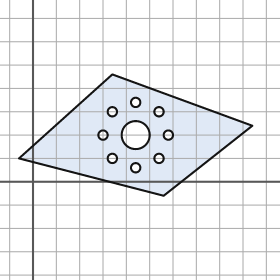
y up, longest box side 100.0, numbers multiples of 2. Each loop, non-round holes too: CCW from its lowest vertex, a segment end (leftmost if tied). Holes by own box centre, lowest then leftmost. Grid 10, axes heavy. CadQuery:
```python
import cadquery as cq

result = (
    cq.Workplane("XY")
    .moveTo(56.0, -6.0)
    .lineTo(94.0, 24.0)
    .lineTo(34.0, 46.0)
    .lineTo(-6.0, 10.0)
    .close()
    .moveTo(44.0, 6.0)
    .circle(2.0)
    .moveTo(34.0, 10.0)
    .circle(2.0)
    .moveTo(54.0, 10.0)
    .circle(2.0)
    .moveTo(30.0, 20.0)
    .circle(2.0)
    .moveTo(44.0, 20.0)
    .circle(6.0)
    .moveTo(58.0, 20.0)
    .circle(2.0)
    .moveTo(34.0, 30.0)
    .circle(2.0)
    .moveTo(54.0, 30.0)
    .circle(2.0)
    .moveTo(44.0, 34.0)
    .circle(2.0)
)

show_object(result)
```